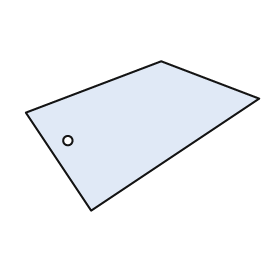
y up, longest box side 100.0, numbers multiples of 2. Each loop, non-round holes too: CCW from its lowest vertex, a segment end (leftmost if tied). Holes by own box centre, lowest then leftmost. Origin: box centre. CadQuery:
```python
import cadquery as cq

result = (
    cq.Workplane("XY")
    .moveTo(-22.0, -32.0)
    .lineTo(50.0, 16.0)
    .lineTo(8.0, 32.0)
    .lineTo(-50.0, 10.0)
    .close()
    .moveTo(-32.0, -2.0)
    .circle(2.0)
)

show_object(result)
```